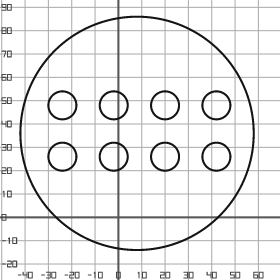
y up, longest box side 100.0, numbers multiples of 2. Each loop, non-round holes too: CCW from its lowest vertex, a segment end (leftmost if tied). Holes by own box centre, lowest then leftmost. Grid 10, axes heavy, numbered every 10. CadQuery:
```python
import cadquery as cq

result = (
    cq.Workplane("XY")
    .moveTo(8.0, 36.0)
    .circle(50.0)
    .moveTo(-24.0, 26.0)
    .circle(6.0)
    .moveTo(-2.0, 26.0)
    .circle(6.0)
    .moveTo(20.0, 26.0)
    .circle(6.0)
    .moveTo(42.0, 26.0)
    .circle(6.0)
    .moveTo(-24.0, 48.0)
    .circle(6.0)
    .moveTo(-2.0, 48.0)
    .circle(6.0)
    .moveTo(20.0, 48.0)
    .circle(6.0)
    .moveTo(42.0, 48.0)
    .circle(6.0)
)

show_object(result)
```